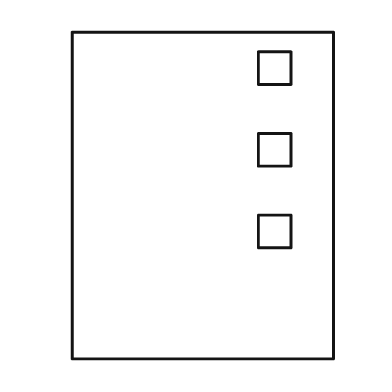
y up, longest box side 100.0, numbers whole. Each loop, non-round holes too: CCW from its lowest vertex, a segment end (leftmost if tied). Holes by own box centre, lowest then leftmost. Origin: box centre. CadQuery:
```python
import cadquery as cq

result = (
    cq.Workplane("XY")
    .moveTo(-40.0, -50.0)
    .lineTo(40.0, -50.0)
    .lineTo(40.0, 50.0)
    .lineTo(-40.0, 50.0)
    .close()
    .moveTo(17.0, -16.0)
    .lineTo(27.0, -16.0)
    .lineTo(27.0, -6.0)
    .lineTo(17.0, -6.0)
    .close()
    .moveTo(17.0, 9.0)
    .lineTo(27.0, 9.0)
    .lineTo(27.0, 19.0)
    .lineTo(17.0, 19.0)
    .close()
    .moveTo(17.0, 34.0)
    .lineTo(27.0, 34.0)
    .lineTo(27.0, 44.0)
    .lineTo(17.0, 44.0)
    .close()
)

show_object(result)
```